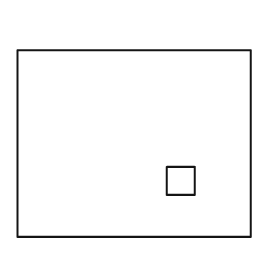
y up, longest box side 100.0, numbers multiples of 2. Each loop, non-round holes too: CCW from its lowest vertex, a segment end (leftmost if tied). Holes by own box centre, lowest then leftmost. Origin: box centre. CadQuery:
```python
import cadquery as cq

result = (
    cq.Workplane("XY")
    .moveTo(-50.0, -40.0)
    .lineTo(50.0, -40.0)
    .lineTo(50.0, 40.0)
    .lineTo(-50.0, 40.0)
    .close()
    .moveTo(14.0, -22.0)
    .lineTo(26.0, -22.0)
    .lineTo(26.0, -10.0)
    .lineTo(14.0, -10.0)
    .close()
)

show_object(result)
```